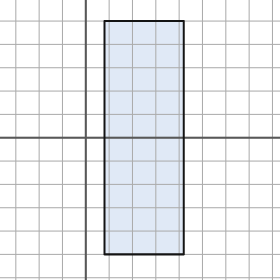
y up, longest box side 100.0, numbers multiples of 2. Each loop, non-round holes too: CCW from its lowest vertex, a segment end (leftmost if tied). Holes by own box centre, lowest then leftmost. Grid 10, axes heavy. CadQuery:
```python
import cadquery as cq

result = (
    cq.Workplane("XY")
    .moveTo(8.0, -50.0)
    .lineTo(42.0, -50.0)
    .lineTo(42.0, 50.0)
    .lineTo(8.0, 50.0)
    .close()
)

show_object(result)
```